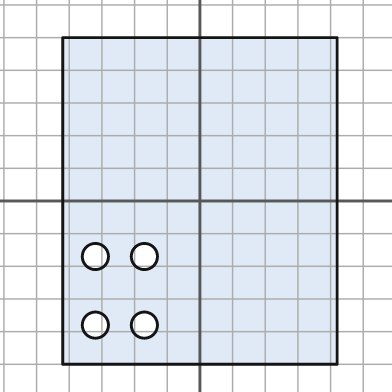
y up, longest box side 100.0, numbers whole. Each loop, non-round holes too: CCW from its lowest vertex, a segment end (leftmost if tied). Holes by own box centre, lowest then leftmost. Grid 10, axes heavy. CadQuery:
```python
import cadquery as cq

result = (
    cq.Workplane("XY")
    .moveTo(-42.0, -50.0)
    .lineTo(42.0, -50.0)
    .lineTo(42.0, 50.0)
    .lineTo(-42.0, 50.0)
    .close()
    .moveTo(-32.0, -38.0)
    .circle(4.0)
    .moveTo(-17.0, -38.0)
    .circle(4.0)
    .moveTo(-32.0, -17.0)
    .circle(4.0)
    .moveTo(-17.0, -17.0)
    .circle(4.0)
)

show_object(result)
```